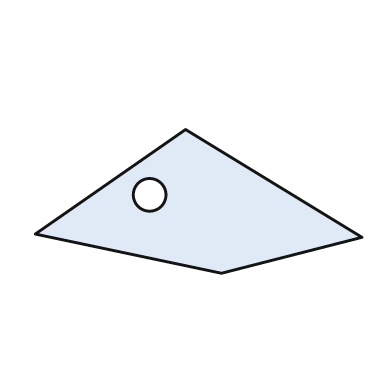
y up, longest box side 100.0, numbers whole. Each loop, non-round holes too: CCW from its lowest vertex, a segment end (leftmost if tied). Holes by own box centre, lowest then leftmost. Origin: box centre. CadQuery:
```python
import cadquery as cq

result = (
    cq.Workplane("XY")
    .moveTo(7.0, -22.0)
    .lineTo(50.0, -11.0)
    .lineTo(-4.0, 22.0)
    .lineTo(-50.0, -10.0)
    .close()
    .moveTo(-15.0, 2.0)
    .circle(5.0)
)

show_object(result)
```